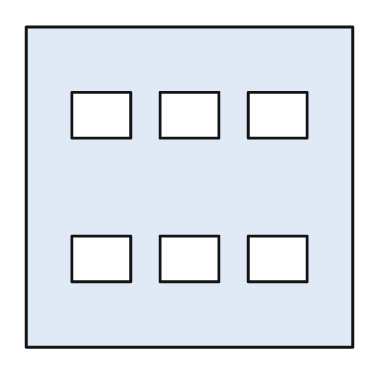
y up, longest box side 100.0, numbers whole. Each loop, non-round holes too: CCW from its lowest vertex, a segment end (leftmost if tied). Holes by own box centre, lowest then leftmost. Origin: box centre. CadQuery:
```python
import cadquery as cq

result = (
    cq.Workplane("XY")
    .moveTo(-50.0, -49.0)
    .lineTo(50.0, -49.0)
    .lineTo(50.0, 49.0)
    .lineTo(-50.0, 49.0)
    .close()
    .moveTo(-36.0, -29.0)
    .lineTo(-18.0, -29.0)
    .lineTo(-18.0, -15.0)
    .lineTo(-36.0, -15.0)
    .close()
    .moveTo(-9.0, -29.0)
    .lineTo(9.0, -29.0)
    .lineTo(9.0, -15.0)
    .lineTo(-9.0, -15.0)
    .close()
    .moveTo(18.0, -29.0)
    .lineTo(36.0, -29.0)
    .lineTo(36.0, -15.0)
    .lineTo(18.0, -15.0)
    .close()
    .moveTo(-36.0, 15.0)
    .lineTo(-18.0, 15.0)
    .lineTo(-18.0, 29.0)
    .lineTo(-36.0, 29.0)
    .close()
    .moveTo(-9.0, 15.0)
    .lineTo(9.0, 15.0)
    .lineTo(9.0, 29.0)
    .lineTo(-9.0, 29.0)
    .close()
    .moveTo(18.0, 15.0)
    .lineTo(36.0, 15.0)
    .lineTo(36.0, 29.0)
    .lineTo(18.0, 29.0)
    .close()
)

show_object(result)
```